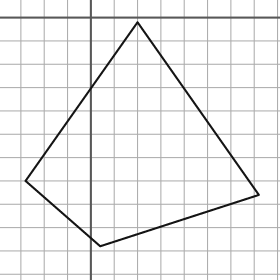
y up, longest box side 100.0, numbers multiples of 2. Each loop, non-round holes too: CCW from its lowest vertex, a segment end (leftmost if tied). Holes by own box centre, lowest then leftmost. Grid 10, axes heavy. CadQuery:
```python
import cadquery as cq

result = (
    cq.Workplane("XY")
    .moveTo(4.0, -98.0)
    .lineTo(72.0, -76.0)
    .lineTo(20.0, -2.0)
    .lineTo(-28.0, -70.0)
    .close()
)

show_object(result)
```